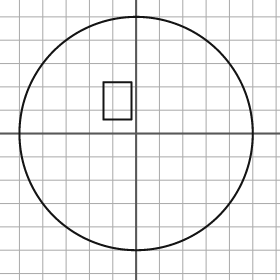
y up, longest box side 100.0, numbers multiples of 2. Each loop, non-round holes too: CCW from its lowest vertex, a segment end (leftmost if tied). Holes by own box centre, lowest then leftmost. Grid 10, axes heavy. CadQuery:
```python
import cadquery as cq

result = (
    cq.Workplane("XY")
    .moveTo(0.0, 0.0)
    .circle(50.0)
    .moveTo(-14.0, 6.0)
    .lineTo(-2.0, 6.0)
    .lineTo(-2.0, 22.0)
    .lineTo(-14.0, 22.0)
    .close()
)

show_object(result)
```